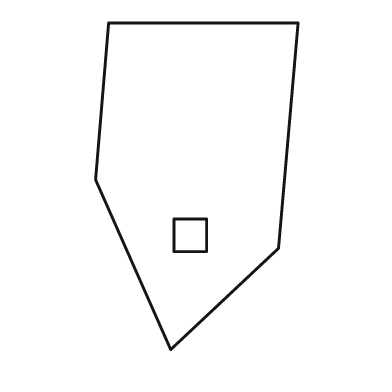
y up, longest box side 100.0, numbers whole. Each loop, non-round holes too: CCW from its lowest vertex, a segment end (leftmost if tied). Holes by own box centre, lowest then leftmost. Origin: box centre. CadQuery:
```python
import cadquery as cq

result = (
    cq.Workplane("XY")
    .moveTo(-8.0, -50.0)
    .lineTo(25.0, -19.0)
    .lineTo(31.0, 50.0)
    .lineTo(-27.0, 50.0)
    .lineTo(-31.0, 2.0)
    .close()
    .moveTo(-7.0, -20.0)
    .lineTo(3.0, -20.0)
    .lineTo(3.0, -10.0)
    .lineTo(-7.0, -10.0)
    .close()
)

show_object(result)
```